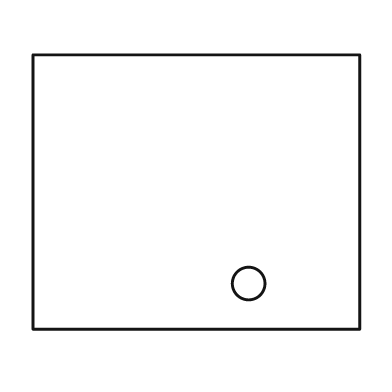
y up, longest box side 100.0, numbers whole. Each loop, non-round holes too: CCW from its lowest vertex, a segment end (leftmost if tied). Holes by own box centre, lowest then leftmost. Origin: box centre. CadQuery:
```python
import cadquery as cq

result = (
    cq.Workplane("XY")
    .moveTo(-50.0, -42.0)
    .lineTo(50.0, -42.0)
    .lineTo(50.0, 42.0)
    .lineTo(-50.0, 42.0)
    .close()
    .moveTo(16.0, -28.0)
    .circle(5.0)
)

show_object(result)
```